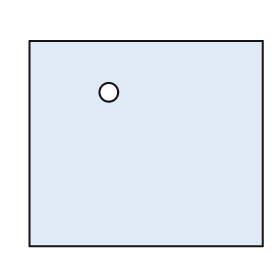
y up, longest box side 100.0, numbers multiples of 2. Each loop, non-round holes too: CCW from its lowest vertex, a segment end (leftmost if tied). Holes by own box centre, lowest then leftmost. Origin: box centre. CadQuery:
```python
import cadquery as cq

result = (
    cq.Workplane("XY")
    .moveTo(-50.0, -44.0)
    .lineTo(50.0, -44.0)
    .lineTo(50.0, 44.0)
    .lineTo(-50.0, 44.0)
    .close()
    .moveTo(-16.0, 22.0)
    .circle(4.0)
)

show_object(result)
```